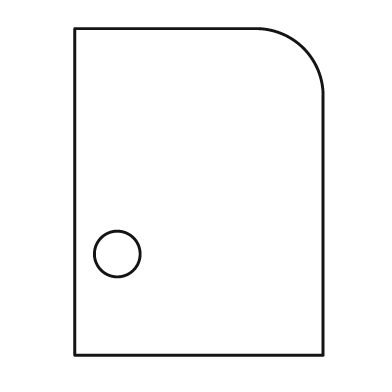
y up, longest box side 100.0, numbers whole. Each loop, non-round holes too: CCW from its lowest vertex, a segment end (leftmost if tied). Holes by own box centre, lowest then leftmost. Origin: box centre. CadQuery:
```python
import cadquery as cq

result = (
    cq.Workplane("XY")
    .moveTo(-38.0, -50.0)
    .lineTo(38.0, -50.0)
    .lineTo(38.0, 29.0)
    .threePointArc((32.0, 44.0), (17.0, 50.0))
    .lineTo(-38.0, 50.0)
    .close()
    .moveTo(-25.0, -19.0)
    .circle(7.0)
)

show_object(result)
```